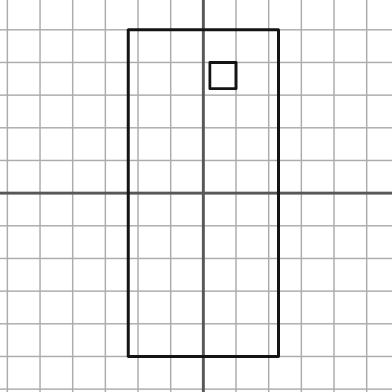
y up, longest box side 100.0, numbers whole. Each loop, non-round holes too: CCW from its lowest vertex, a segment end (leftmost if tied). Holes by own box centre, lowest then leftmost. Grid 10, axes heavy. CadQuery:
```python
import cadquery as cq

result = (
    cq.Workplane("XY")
    .moveTo(-23.0, -50.0)
    .lineTo(23.0, -50.0)
    .lineTo(23.0, 50.0)
    .lineTo(-23.0, 50.0)
    .close()
    .moveTo(2.0, 32.0)
    .lineTo(10.0, 32.0)
    .lineTo(10.0, 40.0)
    .lineTo(2.0, 40.0)
    .close()
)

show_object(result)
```